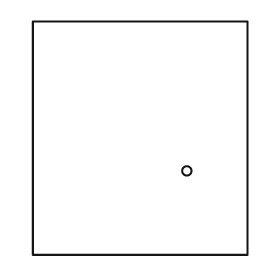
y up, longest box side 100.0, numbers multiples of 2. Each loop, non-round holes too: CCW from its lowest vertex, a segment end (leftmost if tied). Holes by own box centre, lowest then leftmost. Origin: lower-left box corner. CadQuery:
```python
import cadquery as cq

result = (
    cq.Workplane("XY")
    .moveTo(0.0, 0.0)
    .lineTo(92.0, 0.0)
    .lineTo(92.0, 100.0)
    .lineTo(0.0, 100.0)
    .close()
    .moveTo(66.0, 36.0)
    .circle(2.0)
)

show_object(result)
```